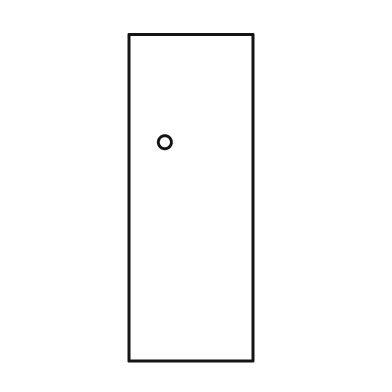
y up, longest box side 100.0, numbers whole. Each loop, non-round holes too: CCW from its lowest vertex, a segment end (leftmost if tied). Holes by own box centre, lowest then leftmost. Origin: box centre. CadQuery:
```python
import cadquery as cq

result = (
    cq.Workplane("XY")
    .moveTo(-19.0, -50.0)
    .lineTo(19.0, -50.0)
    .lineTo(19.0, 50.0)
    .lineTo(-19.0, 50.0)
    .close()
    .moveTo(-8.0, 17.0)
    .circle(2.0)
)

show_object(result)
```